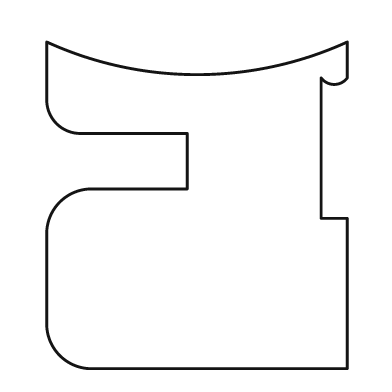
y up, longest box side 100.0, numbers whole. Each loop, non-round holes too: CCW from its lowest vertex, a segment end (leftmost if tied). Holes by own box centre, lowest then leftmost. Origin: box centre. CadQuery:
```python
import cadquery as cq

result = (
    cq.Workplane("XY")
    .moveTo(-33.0, -50.0)
    .lineTo(46.0, -50.0)
    .lineTo(46.0, -4.0)
    .lineTo(38.0, -4.0)
    .lineTo(38.0, 39.0)
    .threePointArc((42.0, 37.0), (46.0, 39.0))
    .lineTo(46.0, 50.0)
    .threePointArc((0.0, 40.0), (-46.0, 50.0))
    .lineTo(-46.0, 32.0)
    .threePointArc((-43.0, 25.0), (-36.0, 22.0))
    .lineTo(-3.0, 22.0)
    .lineTo(-3.0, 5.0)
    .lineTo(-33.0, 5.0)
    .threePointArc((-42.0, 1.0), (-46.0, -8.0))
    .lineTo(-46.0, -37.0)
    .threePointArc((-42.0, -46.0), (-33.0, -50.0))
    .close()
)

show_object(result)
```